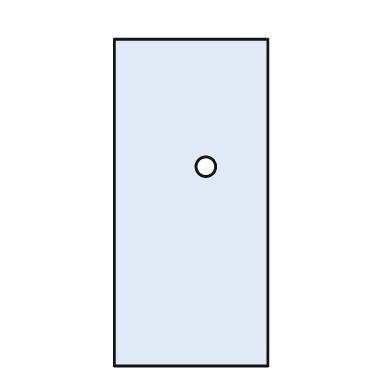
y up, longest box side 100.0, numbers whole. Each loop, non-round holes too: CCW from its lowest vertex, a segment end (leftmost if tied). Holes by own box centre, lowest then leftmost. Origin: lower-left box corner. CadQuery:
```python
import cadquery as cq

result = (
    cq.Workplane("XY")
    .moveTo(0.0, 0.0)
    .lineTo(47.0, 0.0)
    .lineTo(47.0, 100.0)
    .lineTo(0.0, 100.0)
    .close()
    .moveTo(28.0, 61.0)
    .circle(3.0)
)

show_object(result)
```